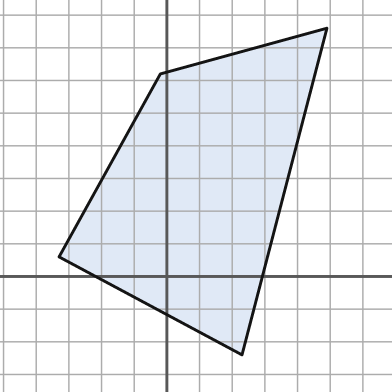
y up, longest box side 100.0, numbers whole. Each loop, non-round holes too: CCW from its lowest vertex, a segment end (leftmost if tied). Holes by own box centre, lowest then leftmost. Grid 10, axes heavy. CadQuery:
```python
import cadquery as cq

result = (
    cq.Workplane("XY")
    .moveTo(23.0, -24.0)
    .lineTo(49.0, 76.0)
    .lineTo(-2.0, 62.0)
    .lineTo(-33.0, 6.0)
    .close()
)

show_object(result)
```